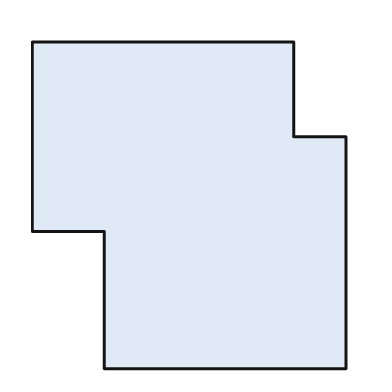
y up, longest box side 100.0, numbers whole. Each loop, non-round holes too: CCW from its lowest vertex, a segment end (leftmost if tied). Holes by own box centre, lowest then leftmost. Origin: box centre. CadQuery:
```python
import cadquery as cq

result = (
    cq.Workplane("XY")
    .moveTo(-26.0, -50.0)
    .lineTo(48.0, -50.0)
    .lineTo(48.0, 21.0)
    .lineTo(32.0, 21.0)
    .lineTo(32.0, 50.0)
    .lineTo(-48.0, 50.0)
    .lineTo(-48.0, -8.0)
    .lineTo(-26.0, -8.0)
    .close()
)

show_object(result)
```